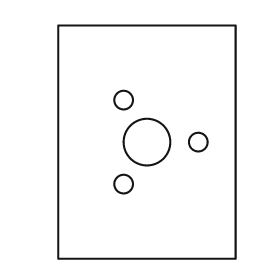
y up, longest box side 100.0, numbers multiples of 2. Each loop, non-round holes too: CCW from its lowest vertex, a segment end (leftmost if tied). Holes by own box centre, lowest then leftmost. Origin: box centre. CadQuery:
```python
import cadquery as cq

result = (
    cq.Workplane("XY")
    .moveTo(-38.0, -50.0)
    .lineTo(38.0, -50.0)
    .lineTo(38.0, 50.0)
    .lineTo(-38.0, 50.0)
    .close()
    .moveTo(-10.0, -18.0)
    .circle(4.0)
    .moveTo(0.0, 0.0)
    .circle(10.0)
    .moveTo(22.0, 0.0)
    .circle(4.0)
    .moveTo(-10.0, 18.0)
    .circle(4.0)
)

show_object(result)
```